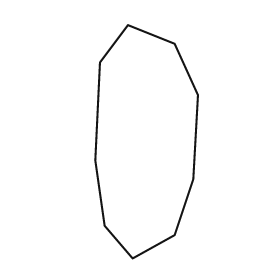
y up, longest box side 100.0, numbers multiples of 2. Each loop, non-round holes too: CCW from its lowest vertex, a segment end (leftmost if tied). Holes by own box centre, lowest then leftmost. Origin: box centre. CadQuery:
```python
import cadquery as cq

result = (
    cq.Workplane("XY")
    .moveTo(-6.0, -50.0)
    .lineTo(12.0, -40.0)
    .lineTo(20.0, -16.0)
    .lineTo(22.0, 20.0)
    .lineTo(12.0, 42.0)
    .lineTo(-8.0, 50.0)
    .lineTo(-20.0, 34.0)
    .lineTo(-22.0, -8.0)
    .lineTo(-18.0, -36.0)
    .close()
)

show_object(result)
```